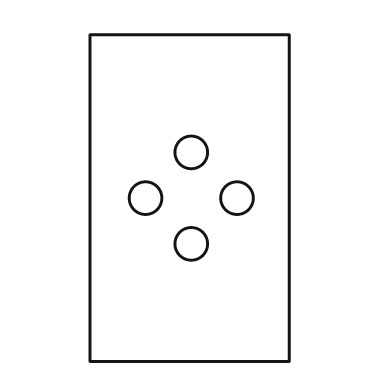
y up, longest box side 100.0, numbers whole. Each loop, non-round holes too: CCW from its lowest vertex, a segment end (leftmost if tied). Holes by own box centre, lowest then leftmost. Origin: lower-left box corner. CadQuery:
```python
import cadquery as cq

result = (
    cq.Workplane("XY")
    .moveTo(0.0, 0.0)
    .lineTo(61.0, 0.0)
    .lineTo(61.0, 100.0)
    .lineTo(0.0, 100.0)
    .close()
    .moveTo(31.0, 36.0)
    .circle(5.0)
    .moveTo(17.0, 50.0)
    .circle(5.0)
    .moveTo(45.0, 50.0)
    .circle(5.0)
    .moveTo(31.0, 64.0)
    .circle(5.0)
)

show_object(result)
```